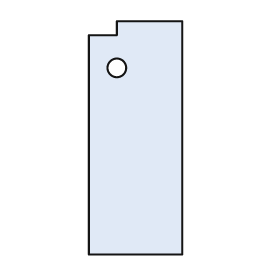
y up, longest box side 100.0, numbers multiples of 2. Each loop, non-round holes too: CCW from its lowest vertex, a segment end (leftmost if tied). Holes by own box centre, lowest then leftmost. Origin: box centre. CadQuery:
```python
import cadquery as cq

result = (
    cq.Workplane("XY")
    .moveTo(-20.0, -50.0)
    .lineTo(20.0, -50.0)
    .lineTo(20.0, 50.0)
    .lineTo(-8.0, 50.0)
    .lineTo(-8.0, 44.0)
    .lineTo(-20.0, 44.0)
    .close()
    .moveTo(-8.0, 30.0)
    .circle(4.0)
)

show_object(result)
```